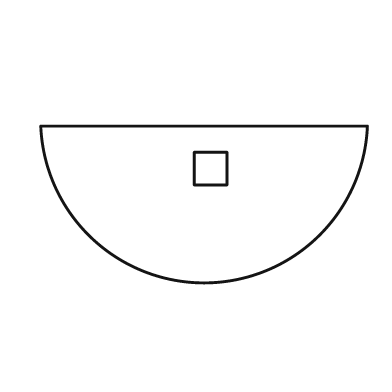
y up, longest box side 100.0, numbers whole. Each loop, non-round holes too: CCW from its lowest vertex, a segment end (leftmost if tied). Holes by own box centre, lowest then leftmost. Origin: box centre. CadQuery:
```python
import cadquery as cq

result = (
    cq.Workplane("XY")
    .moveTo(-50.0, 24.0)
    .threePointArc((0.0, -24.0), (50.0, 24.0))
    .close()
    .moveTo(-3.0, 6.0)
    .lineTo(7.0, 6.0)
    .lineTo(7.0, 16.0)
    .lineTo(-3.0, 16.0)
    .close()
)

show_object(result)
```